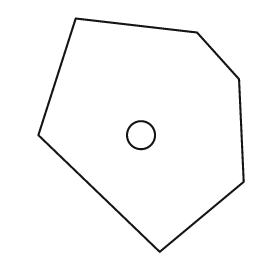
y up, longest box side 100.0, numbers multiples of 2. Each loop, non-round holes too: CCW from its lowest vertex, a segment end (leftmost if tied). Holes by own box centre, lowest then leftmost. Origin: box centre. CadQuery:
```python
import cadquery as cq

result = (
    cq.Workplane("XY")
    .moveTo(8.0, -50.0)
    .lineTo(44.0, -20.0)
    .lineTo(42.0, 24.0)
    .lineTo(24.0, 44.0)
    .lineTo(-28.0, 50.0)
    .lineTo(-44.0, 0.0)
    .close()
    .moveTo(0.0, 0.0)
    .circle(6.0)
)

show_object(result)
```